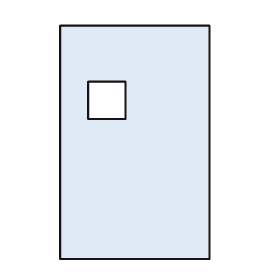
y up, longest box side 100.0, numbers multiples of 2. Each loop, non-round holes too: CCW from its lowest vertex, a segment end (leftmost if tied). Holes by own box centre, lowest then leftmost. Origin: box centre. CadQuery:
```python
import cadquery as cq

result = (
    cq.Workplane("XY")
    .moveTo(-32.0, -50.0)
    .lineTo(32.0, -50.0)
    .lineTo(32.0, 50.0)
    .lineTo(-32.0, 50.0)
    .close()
    .moveTo(-20.0, 10.0)
    .lineTo(-4.0, 10.0)
    .lineTo(-4.0, 26.0)
    .lineTo(-20.0, 26.0)
    .close()
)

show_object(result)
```